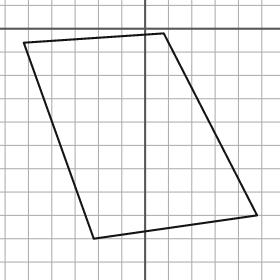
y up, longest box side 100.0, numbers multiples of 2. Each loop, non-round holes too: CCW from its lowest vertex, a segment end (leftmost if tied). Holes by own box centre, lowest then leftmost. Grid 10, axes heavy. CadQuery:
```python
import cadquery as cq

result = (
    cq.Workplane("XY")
    .moveTo(-22.0, -90.0)
    .lineTo(48.0, -80.0)
    .lineTo(8.0, -2.0)
    .lineTo(-52.0, -6.0)
    .close()
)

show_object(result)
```